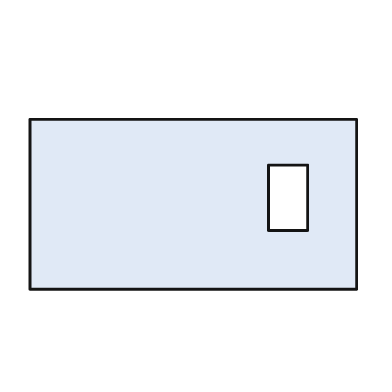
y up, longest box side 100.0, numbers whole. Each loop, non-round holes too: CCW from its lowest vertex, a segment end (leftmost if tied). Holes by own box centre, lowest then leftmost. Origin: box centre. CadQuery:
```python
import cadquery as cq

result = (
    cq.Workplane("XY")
    .moveTo(-50.0, -26.0)
    .lineTo(50.0, -26.0)
    .lineTo(50.0, 26.0)
    .lineTo(-50.0, 26.0)
    .close()
    .moveTo(23.0, -8.0)
    .lineTo(35.0, -8.0)
    .lineTo(35.0, 12.0)
    .lineTo(23.0, 12.0)
    .close()
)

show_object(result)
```